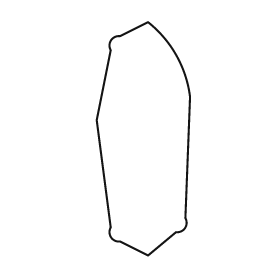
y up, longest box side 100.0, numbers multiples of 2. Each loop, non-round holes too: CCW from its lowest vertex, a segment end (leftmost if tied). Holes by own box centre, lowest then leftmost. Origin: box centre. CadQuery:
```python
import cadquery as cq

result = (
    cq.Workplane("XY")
    .moveTo(2.0, -50.0)
    .lineTo(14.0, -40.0)
    .threePointArc((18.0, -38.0), (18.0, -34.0))
    .lineTo(20.0, 18.0)
    .threePointArc((14.0, 36.0), (2.0, 50.0))
    .lineTo(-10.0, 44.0)
    .threePointArc((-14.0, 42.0), (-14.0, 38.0))
    .lineTo(-20.0, 8.0)
    .lineTo(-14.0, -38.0)
    .threePointArc((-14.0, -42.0), (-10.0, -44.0))
    .close()
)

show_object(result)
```